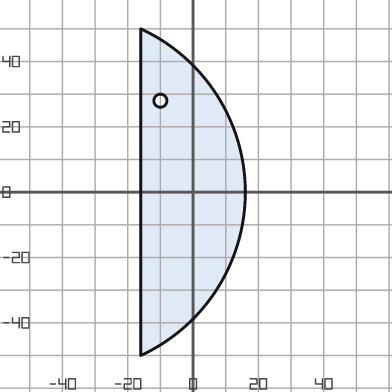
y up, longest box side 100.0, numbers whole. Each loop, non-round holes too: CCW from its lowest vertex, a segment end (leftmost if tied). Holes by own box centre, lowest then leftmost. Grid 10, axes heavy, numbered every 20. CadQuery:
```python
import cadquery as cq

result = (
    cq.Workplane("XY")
    .moveTo(-16.0, -50.0)
    .threePointArc((16.0, 0.0), (-16.0, 50.0))
    .close()
    .moveTo(-10.0, 28.0)
    .circle(2.0)
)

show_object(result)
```